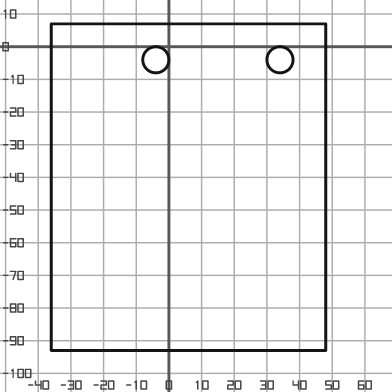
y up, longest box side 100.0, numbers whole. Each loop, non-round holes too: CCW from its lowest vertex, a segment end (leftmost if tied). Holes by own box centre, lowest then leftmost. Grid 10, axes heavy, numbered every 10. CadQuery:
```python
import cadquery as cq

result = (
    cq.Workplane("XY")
    .moveTo(-36.0, -93.0)
    .lineTo(48.0, -93.0)
    .lineTo(48.0, 7.0)
    .lineTo(-36.0, 7.0)
    .close()
    .moveTo(-4.0, -4.0)
    .circle(4.0)
    .moveTo(34.0, -4.0)
    .circle(4.0)
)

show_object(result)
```